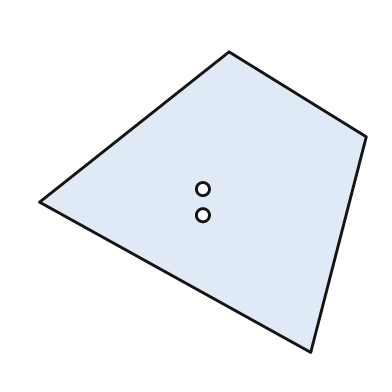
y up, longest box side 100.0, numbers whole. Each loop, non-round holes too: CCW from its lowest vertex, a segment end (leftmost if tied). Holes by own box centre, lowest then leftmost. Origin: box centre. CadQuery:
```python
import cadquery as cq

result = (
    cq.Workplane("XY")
    .moveTo(33.0, -46.0)
    .lineTo(50.0, 20.0)
    .lineTo(8.0, 46.0)
    .lineTo(-50.0, 0.0)
    .close()
    .moveTo(0.0, -4.0)
    .circle(2.0)
    .moveTo(0.0, 4.0)
    .circle(2.0)
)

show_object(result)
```